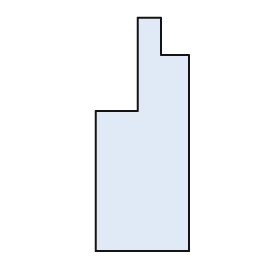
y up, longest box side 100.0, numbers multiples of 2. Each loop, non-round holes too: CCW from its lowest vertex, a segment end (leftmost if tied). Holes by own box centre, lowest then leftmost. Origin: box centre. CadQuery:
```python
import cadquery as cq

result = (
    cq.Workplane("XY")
    .moveTo(-20.0, -50.0)
    .lineTo(20.0, -50.0)
    .lineTo(20.0, 34.0)
    .lineTo(8.0, 34.0)
    .lineTo(8.0, 50.0)
    .lineTo(-2.0, 50.0)
    .lineTo(-2.0, 10.0)
    .lineTo(-20.0, 10.0)
    .close()
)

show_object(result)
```